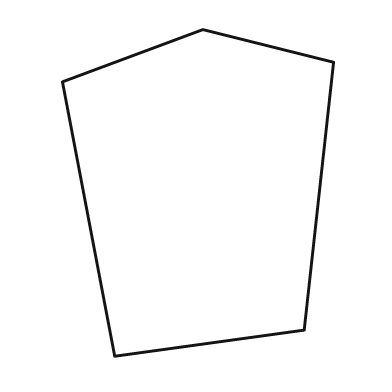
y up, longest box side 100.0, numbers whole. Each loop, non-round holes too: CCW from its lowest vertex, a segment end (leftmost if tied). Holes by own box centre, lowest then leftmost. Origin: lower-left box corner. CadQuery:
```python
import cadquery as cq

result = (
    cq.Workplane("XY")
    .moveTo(16.0, 0.0)
    .lineTo(74.0, 8.0)
    .lineTo(83.0, 90.0)
    .lineTo(43.0, 100.0)
    .lineTo(0.0, 84.0)
    .close()
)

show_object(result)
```